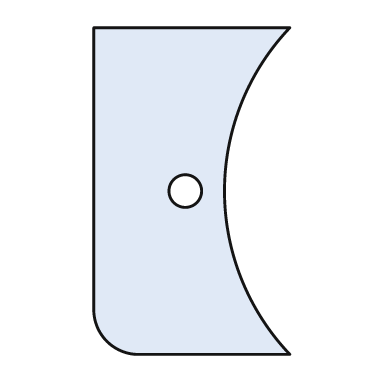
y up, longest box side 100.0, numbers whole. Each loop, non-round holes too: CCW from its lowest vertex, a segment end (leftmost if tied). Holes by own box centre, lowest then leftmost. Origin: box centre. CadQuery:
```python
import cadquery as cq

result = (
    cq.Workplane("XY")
    .moveTo(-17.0, -50.0)
    .lineTo(30.0, -50.0)
    .threePointArc((10.0, 0.0), (30.0, 50.0))
    .lineTo(-30.0, 50.0)
    .lineTo(-30.0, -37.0)
    .threePointArc((-26.0, -46.0), (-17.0, -50.0))
    .close()
    .moveTo(-2.0, 0.0)
    .circle(5.0)
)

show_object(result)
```